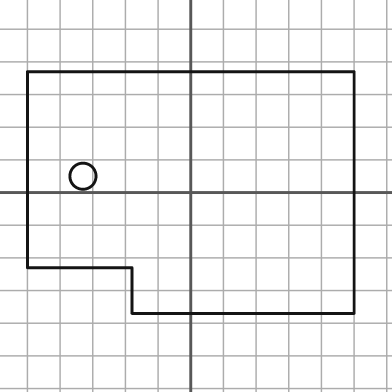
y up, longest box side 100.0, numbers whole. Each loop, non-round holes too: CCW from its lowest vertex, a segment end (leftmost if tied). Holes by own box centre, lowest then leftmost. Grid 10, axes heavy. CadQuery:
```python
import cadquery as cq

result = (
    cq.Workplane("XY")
    .moveTo(-18.0, -37.0)
    .lineTo(50.0, -37.0)
    .lineTo(50.0, 37.0)
    .lineTo(-50.0, 37.0)
    .lineTo(-50.0, -23.0)
    .lineTo(-18.0, -23.0)
    .close()
    .moveTo(-33.0, 5.0)
    .circle(4.0)
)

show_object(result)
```